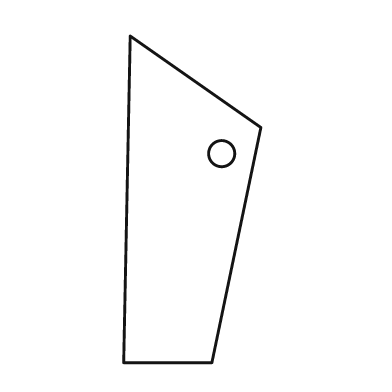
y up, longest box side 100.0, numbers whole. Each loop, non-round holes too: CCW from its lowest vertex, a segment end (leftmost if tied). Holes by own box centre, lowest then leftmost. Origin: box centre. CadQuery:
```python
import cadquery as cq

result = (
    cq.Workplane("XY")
    .moveTo(-21.0, -50.0)
    .lineTo(6.0, -50.0)
    .lineTo(21.0, 22.0)
    .lineTo(-19.0, 50.0)
    .close()
    .moveTo(9.0, 14.0)
    .circle(4.0)
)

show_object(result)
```